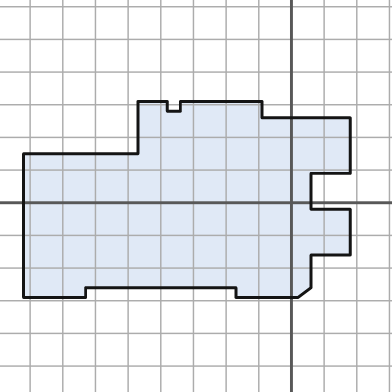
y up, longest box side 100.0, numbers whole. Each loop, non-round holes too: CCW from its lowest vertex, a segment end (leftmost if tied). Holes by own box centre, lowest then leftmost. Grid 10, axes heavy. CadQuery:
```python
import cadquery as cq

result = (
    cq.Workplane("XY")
    .moveTo(-82.0, -29.0)
    .lineTo(-63.0, -29.0)
    .lineTo(-63.0, -26.0)
    .lineTo(-17.0, -26.0)
    .lineTo(-17.0, -29.0)
    .lineTo(2.0, -29.0)
    .lineTo(6.0, -26.0)
    .lineTo(6.0, -16.0)
    .lineTo(18.0, -16.0)
    .lineTo(18.0, -2.0)
    .lineTo(6.0, -2.0)
    .lineTo(6.0, 9.0)
    .lineTo(18.0, 9.0)
    .lineTo(18.0, 26.0)
    .lineTo(-9.0, 26.0)
    .lineTo(-9.0, 31.0)
    .lineTo(-34.0, 31.0)
    .lineTo(-34.0, 28.0)
    .lineTo(-38.0, 28.0)
    .lineTo(-38.0, 31.0)
    .lineTo(-47.0, 31.0)
    .lineTo(-47.0, 15.0)
    .lineTo(-82.0, 15.0)
    .close()
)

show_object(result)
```